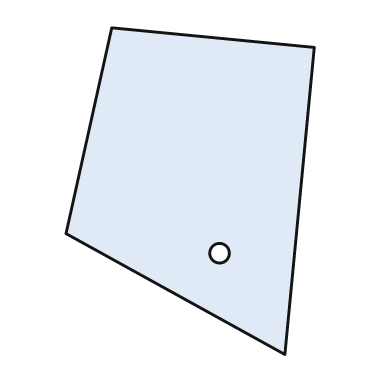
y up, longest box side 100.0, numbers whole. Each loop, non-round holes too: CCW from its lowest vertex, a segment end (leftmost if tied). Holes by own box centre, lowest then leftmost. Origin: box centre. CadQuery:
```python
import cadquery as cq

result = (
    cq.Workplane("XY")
    .moveTo(29.0, -50.0)
    .lineTo(38.0, 44.0)
    .lineTo(-24.0, 50.0)
    .lineTo(-38.0, -13.0)
    .close()
    .moveTo(9.0, -19.0)
    .circle(3.0)
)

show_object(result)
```